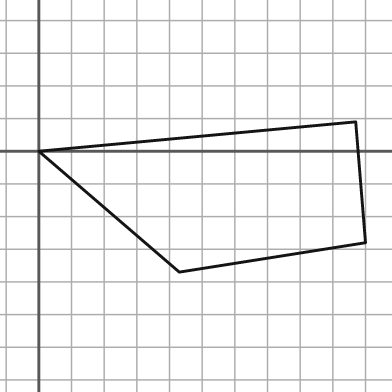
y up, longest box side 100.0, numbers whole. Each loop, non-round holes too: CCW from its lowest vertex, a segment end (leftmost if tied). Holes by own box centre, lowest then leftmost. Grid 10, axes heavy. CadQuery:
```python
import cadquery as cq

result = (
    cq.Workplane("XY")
    .moveTo(43.0, -37.0)
    .lineTo(100.0, -28.0)
    .lineTo(97.0, 9.0)
    .lineTo(0.0, 0.0)
    .close()
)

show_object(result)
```